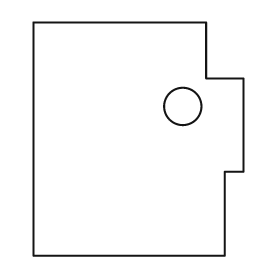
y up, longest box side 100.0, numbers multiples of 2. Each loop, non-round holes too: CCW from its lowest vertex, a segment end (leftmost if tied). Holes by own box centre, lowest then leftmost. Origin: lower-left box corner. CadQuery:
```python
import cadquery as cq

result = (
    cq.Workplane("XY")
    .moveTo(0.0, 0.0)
    .lineTo(82.0, 0.0)
    .lineTo(82.0, 36.0)
    .lineTo(90.0, 36.0)
    .lineTo(90.0, 76.0)
    .lineTo(74.0, 76.0)
    .lineTo(74.0, 100.0)
    .lineTo(0.0, 100.0)
    .close()
    .moveTo(64.0, 64.0)
    .circle(8.0)
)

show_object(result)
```